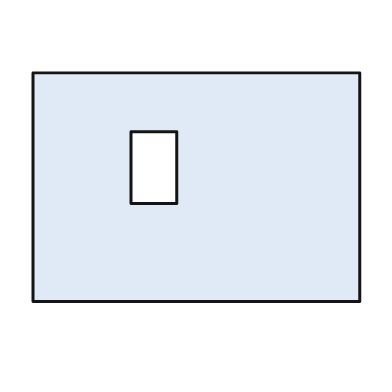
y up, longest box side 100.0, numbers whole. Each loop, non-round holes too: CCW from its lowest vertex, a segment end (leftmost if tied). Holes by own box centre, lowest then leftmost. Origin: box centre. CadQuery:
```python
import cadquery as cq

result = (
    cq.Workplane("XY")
    .moveTo(-50.0, -35.0)
    .lineTo(50.0, -35.0)
    .lineTo(50.0, 35.0)
    .lineTo(-50.0, 35.0)
    .close()
    .moveTo(-20.0, -5.0)
    .lineTo(-6.0, -5.0)
    .lineTo(-6.0, 17.0)
    .lineTo(-20.0, 17.0)
    .close()
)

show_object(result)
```